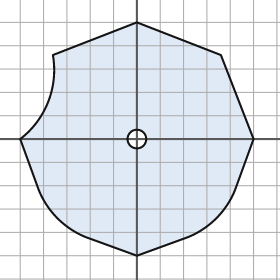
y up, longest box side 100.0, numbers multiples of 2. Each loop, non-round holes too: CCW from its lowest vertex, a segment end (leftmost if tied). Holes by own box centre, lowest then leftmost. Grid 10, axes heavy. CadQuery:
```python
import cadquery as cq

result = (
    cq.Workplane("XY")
    .moveTo(0.0, -50.0)
    .lineTo(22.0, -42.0)
    .threePointArc((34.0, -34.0), (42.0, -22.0))
    .lineTo(50.0, 0.0)
    .lineTo(36.0, 36.0)
    .lineTo(0.0, 50.0)
    .lineTo(-36.0, 36.0)
    .threePointArc((-38.0, 16.0), (-50.0, 0.0))
    .lineTo(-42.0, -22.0)
    .threePointArc((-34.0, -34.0), (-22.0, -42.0))
    .close()
    .moveTo(0.0, 0.0)
    .circle(4.0)
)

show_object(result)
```